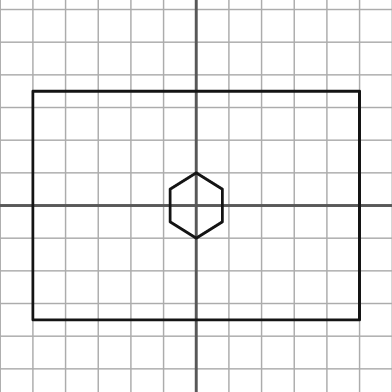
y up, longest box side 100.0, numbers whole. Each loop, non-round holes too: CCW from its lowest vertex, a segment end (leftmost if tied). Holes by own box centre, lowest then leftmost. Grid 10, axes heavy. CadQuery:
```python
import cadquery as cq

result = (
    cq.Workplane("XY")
    .moveTo(-50.0, -35.0)
    .lineTo(50.0, -35.0)
    .lineTo(50.0, 35.0)
    .lineTo(-50.0, 35.0)
    .close()
    .moveTo(0.0, -10.0)
    .lineTo(8.0, -5.0)
    .lineTo(8.0, 5.0)
    .lineTo(0.0, 10.0)
    .lineTo(-8.0, 5.0)
    .lineTo(-8.0, -5.0)
    .close()
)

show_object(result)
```